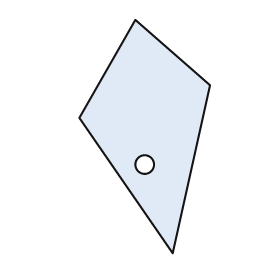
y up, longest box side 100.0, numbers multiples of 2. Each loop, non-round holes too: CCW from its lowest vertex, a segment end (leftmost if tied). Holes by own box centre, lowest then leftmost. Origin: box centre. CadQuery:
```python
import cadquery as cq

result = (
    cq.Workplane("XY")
    .moveTo(12.0, -50.0)
    .lineTo(28.0, 22.0)
    .lineTo(-4.0, 50.0)
    .lineTo(-28.0, 8.0)
    .close()
    .moveTo(0.0, -12.0)
    .circle(4.0)
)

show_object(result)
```